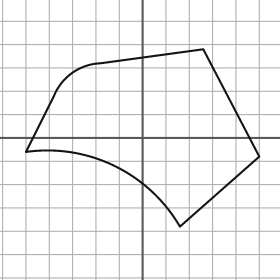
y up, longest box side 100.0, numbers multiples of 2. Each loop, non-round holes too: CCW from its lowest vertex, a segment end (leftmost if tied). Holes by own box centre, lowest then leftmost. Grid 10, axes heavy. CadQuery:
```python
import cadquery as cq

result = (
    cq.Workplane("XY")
    .moveTo(16.0, -38.0)
    .lineTo(50.0, -8.0)
    .lineTo(26.0, 38.0)
    .lineTo(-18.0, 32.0)
    .threePointArc((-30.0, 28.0), (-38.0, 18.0))
    .lineTo(-50.0, -6.0)
    .threePointArc((-12.0, -12.0), (16.0, -38.0))
    .close()
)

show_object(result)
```